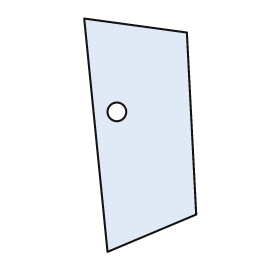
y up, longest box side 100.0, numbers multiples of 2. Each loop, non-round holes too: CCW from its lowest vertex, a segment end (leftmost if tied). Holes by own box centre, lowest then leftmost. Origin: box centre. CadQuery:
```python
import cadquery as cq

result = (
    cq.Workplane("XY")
    .moveTo(-14.0, -50.0)
    .lineTo(24.0, -34.0)
    .lineTo(20.0, 44.0)
    .lineTo(-24.0, 50.0)
    .close()
    .moveTo(-10.0, 10.0)
    .circle(4.0)
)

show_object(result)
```